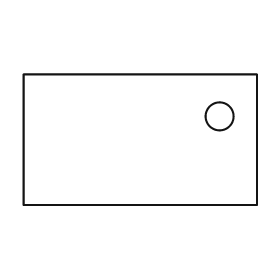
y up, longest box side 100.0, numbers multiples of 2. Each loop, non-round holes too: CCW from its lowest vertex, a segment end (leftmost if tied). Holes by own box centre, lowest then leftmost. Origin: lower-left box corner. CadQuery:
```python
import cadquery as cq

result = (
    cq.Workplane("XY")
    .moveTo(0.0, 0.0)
    .lineTo(100.0, 0.0)
    .lineTo(100.0, 56.0)
    .lineTo(0.0, 56.0)
    .close()
    .moveTo(84.0, 38.0)
    .circle(6.0)
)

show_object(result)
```